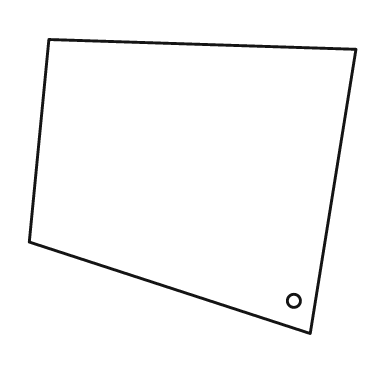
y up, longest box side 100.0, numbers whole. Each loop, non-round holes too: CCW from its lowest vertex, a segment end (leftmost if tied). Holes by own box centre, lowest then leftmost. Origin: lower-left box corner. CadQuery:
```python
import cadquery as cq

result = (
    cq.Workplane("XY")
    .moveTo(86.0, 0.0)
    .lineTo(100.0, 87.0)
    .lineTo(6.0, 90.0)
    .lineTo(0.0, 28.0)
    .close()
    .moveTo(81.0, 10.0)
    .circle(2.0)
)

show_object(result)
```